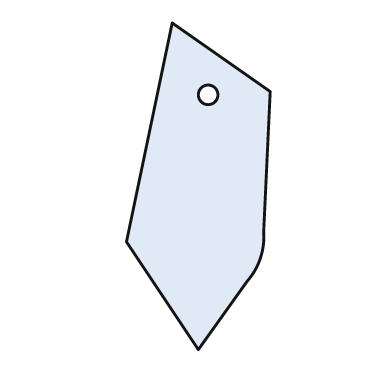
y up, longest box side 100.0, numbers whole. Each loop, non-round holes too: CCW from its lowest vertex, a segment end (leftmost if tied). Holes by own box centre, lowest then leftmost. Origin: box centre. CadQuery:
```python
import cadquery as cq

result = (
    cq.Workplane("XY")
    .moveTo(0.0, -50.0)
    .lineTo(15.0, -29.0)
    .threePointArc((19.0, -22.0), (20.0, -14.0))
    .lineTo(22.0, 29.0)
    .lineTo(-8.0, 50.0)
    .lineTo(-22.0, -17.0)
    .close()
    .moveTo(3.0, 28.0)
    .circle(3.0)
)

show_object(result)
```